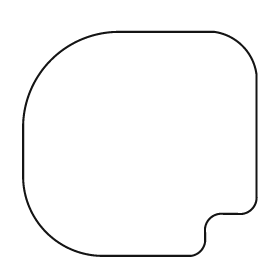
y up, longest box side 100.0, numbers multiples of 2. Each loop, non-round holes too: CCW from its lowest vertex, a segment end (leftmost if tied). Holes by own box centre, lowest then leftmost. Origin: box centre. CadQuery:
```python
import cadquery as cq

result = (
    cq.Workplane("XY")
    .moveTo(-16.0, -48.0)
    .lineTo(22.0, -48.0)
    .threePointArc((26.0, -46.0), (28.0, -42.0))
    .lineTo(28.0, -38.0)
    .threePointArc((30.0, -32.0), (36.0, -30.0))
    .lineTo(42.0, -30.0)
    .threePointArc((48.0, -28.0), (50.0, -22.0))
    .lineTo(50.0, 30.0)
    .threePointArc((44.0, 42.0), (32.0, 48.0))
    .lineTo(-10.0, 48.0)
    .threePointArc((-38.0, 36.0), (-50.0, 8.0))
    .lineTo(-50.0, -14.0)
    .threePointArc((-40.0, -38.0), (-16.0, -48.0))
    .close()
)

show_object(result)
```